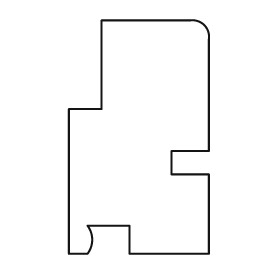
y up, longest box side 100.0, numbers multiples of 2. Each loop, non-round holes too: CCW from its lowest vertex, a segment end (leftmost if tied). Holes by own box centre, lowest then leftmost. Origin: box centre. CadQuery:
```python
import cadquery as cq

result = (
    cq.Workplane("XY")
    .moveTo(-30.0, -50.0)
    .lineTo(-22.0, -50.0)
    .threePointArc((-20.0, -44.0), (-22.0, -38.0))
    .lineTo(-4.0, -38.0)
    .lineTo(-4.0, -50.0)
    .lineTo(30.0, -50.0)
    .lineTo(30.0, -16.0)
    .lineTo(14.0, -16.0)
    .lineTo(14.0, -6.0)
    .lineTo(30.0, -6.0)
    .lineTo(30.0, 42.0)
    .threePointArc((28.0, 48.0), (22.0, 50.0))
    .lineTo(-16.0, 50.0)
    .lineTo(-16.0, 12.0)
    .lineTo(-30.0, 12.0)
    .close()
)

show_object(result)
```